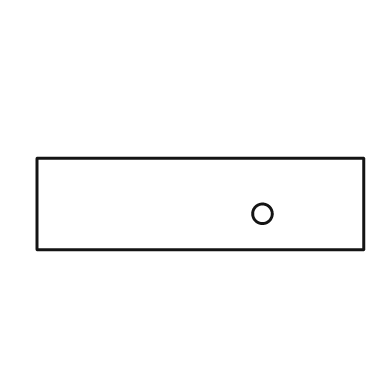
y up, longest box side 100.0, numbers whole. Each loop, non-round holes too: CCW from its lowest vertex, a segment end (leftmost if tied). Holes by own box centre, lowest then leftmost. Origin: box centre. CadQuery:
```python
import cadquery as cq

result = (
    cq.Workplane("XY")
    .moveTo(-50.0, -14.0)
    .lineTo(50.0, -14.0)
    .lineTo(50.0, 14.0)
    .lineTo(-50.0, 14.0)
    .close()
    .moveTo(19.0, -3.0)
    .circle(3.0)
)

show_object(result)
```